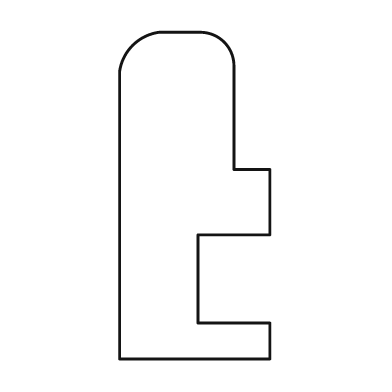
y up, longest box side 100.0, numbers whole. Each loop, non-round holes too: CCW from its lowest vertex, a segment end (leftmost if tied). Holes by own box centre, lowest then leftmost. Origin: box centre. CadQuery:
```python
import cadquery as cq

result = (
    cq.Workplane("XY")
    .moveTo(-23.0, -50.0)
    .lineTo(23.0, -50.0)
    .lineTo(23.0, -39.0)
    .lineTo(1.0, -39.0)
    .lineTo(1.0, -12.0)
    .lineTo(23.0, -12.0)
    .lineTo(23.0, 8.0)
    .lineTo(12.0, 8.0)
    .lineTo(12.0, 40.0)
    .threePointArc((9.0, 47.0), (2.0, 50.0))
    .lineTo(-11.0, 50.0)
    .threePointArc((-19.0, 46.0), (-23.0, 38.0))
    .close()
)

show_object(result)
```